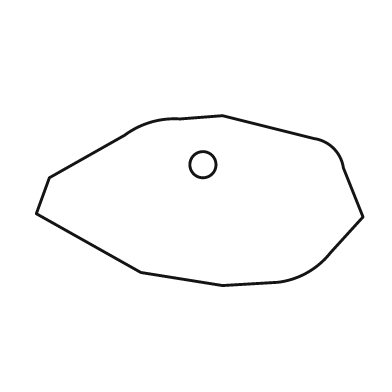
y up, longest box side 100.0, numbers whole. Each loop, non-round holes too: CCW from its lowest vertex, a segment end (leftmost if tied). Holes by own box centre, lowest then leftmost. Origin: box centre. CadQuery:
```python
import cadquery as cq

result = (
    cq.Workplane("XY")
    .moveTo(7.0, -26.0)
    .lineTo(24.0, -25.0)
    .threePointArc((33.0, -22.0), (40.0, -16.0))
    .lineTo(50.0, -5.0)
    .lineTo(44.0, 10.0)
    .threePointArc((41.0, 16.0), (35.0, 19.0))
    .lineTo(7.0, 26.0)
    .lineTo(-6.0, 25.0)
    .threePointArc((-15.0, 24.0), (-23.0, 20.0))
    .lineTo(-46.0, 7.0)
    .lineTo(-50.0, -4.0)
    .lineTo(-18.0, -22.0)
    .close()
    .moveTo(1.0, 11.0)
    .circle(4.0)
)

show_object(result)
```